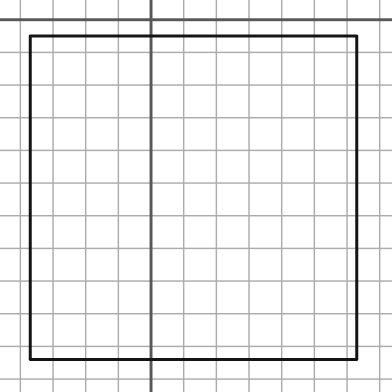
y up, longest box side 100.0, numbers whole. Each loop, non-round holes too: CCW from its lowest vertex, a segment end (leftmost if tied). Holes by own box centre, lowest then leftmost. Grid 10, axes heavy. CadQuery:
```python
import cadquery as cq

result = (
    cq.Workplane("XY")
    .moveTo(-37.0, -104.0)
    .lineTo(63.0, -104.0)
    .lineTo(63.0, -5.0)
    .lineTo(-37.0, -5.0)
    .close()
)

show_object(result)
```